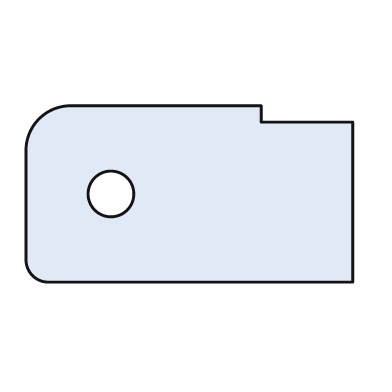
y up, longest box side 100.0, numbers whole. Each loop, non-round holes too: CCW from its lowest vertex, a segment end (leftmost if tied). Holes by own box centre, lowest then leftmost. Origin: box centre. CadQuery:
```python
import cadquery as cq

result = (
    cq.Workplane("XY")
    .moveTo(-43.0, -27.0)
    .lineTo(50.0, -27.0)
    .lineTo(50.0, 22.0)
    .lineTo(22.0, 22.0)
    .lineTo(22.0, 27.0)
    .lineTo(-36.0, 27.0)
    .threePointArc((-46.0, 23.0), (-50.0, 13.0))
    .lineTo(-50.0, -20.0)
    .threePointArc((-48.0, -25.0), (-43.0, -27.0))
    .close()
    .moveTo(-24.0, 0.0)
    .circle(7.0)
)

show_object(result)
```